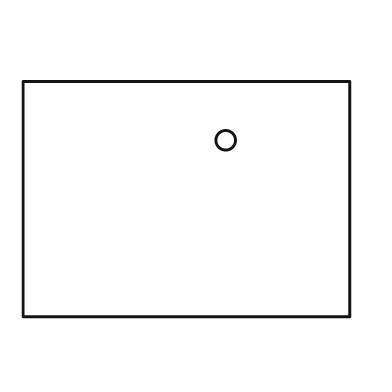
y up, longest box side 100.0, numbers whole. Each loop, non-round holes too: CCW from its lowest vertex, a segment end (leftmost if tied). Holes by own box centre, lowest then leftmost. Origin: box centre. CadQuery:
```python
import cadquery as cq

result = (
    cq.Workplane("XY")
    .moveTo(-50.0, -36.0)
    .lineTo(50.0, -36.0)
    .lineTo(50.0, 36.0)
    .lineTo(-50.0, 36.0)
    .close()
    .moveTo(12.0, 18.0)
    .circle(3.0)
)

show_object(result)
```